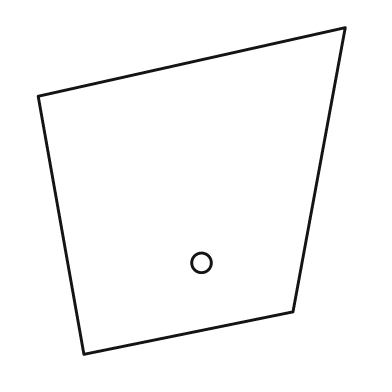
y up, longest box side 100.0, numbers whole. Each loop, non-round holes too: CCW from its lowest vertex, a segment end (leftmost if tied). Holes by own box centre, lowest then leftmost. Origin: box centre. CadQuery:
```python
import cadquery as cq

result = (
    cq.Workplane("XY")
    .moveTo(-33.0, -50.0)
    .lineTo(31.0, -37.0)
    .lineTo(47.0, 50.0)
    .lineTo(-47.0, 29.0)
    .close()
    .moveTo(3.0, -22.0)
    .circle(3.0)
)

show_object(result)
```